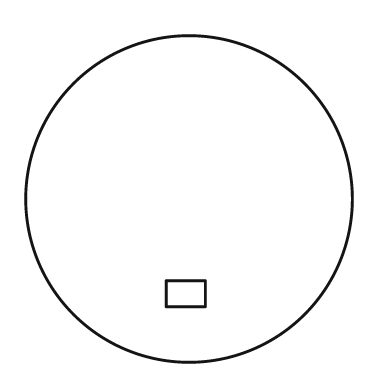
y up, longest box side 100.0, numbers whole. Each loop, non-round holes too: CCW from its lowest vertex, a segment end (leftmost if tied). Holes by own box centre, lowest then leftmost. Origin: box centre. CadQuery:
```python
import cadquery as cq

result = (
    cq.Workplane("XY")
    .moveTo(0.0, 0.0)
    .circle(50.0)
    .moveTo(-7.0, -33.0)
    .lineTo(5.0, -33.0)
    .lineTo(5.0, -25.0)
    .lineTo(-7.0, -25.0)
    .close()
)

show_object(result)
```